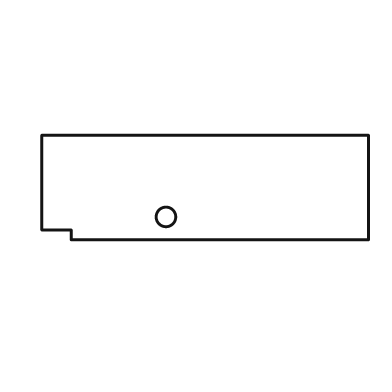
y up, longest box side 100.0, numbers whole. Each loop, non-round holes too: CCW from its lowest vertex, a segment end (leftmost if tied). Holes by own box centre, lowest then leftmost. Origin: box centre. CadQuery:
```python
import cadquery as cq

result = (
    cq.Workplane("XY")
    .moveTo(-41.0, -16.0)
    .lineTo(50.0, -16.0)
    .lineTo(50.0, 16.0)
    .lineTo(-50.0, 16.0)
    .lineTo(-50.0, -13.0)
    .lineTo(-41.0, -13.0)
    .close()
    .moveTo(-12.0, -9.0)
    .circle(3.0)
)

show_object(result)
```